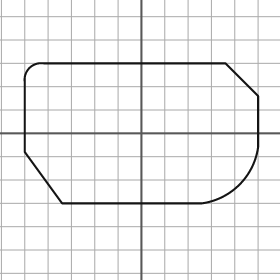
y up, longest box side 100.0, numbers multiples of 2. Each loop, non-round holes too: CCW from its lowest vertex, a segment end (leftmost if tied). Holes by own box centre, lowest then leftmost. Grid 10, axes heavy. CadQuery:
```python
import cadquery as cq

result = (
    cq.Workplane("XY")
    .moveTo(-34.0, -30.0)
    .lineTo(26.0, -30.0)
    .threePointArc((42.0, -22.0), (50.0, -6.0))
    .lineTo(50.0, 16.0)
    .lineTo(36.0, 30.0)
    .lineTo(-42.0, 30.0)
    .threePointArc((-48.0, 28.0), (-50.0, 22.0))
    .lineTo(-50.0, -8.0)
    .close()
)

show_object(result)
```